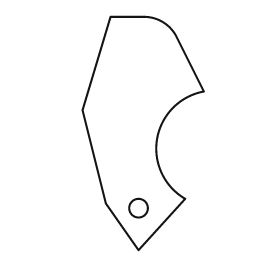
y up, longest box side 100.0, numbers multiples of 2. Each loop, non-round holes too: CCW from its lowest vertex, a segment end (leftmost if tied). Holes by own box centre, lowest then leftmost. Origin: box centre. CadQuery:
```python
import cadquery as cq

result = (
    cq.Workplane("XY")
    .moveTo(-2.0, -50.0)
    .lineTo(18.0, -28.0)
    .threePointArc((6.0, -2.0), (26.0, 18.0))
    .lineTo(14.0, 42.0)
    .threePointArc((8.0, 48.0), (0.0, 50.0))
    .lineTo(-14.0, 50.0)
    .lineTo(-26.0, 10.0)
    .lineTo(-16.0, -30.0)
    .close()
    .moveTo(-2.0, -32.0)
    .circle(4.0)
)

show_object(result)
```